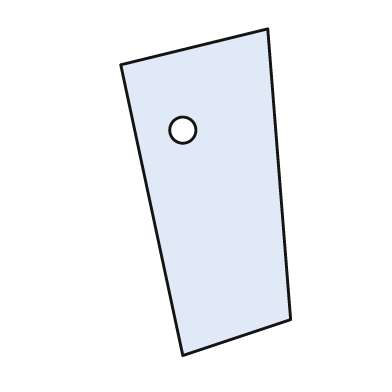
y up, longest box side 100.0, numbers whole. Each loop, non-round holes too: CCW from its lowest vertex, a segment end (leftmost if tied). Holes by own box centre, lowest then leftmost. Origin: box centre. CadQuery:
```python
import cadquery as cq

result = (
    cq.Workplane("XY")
    .moveTo(-7.0, -50.0)
    .lineTo(26.0, -39.0)
    .lineTo(19.0, 50.0)
    .lineTo(-26.0, 39.0)
    .close()
    .moveTo(-7.0, 19.0)
    .circle(4.0)
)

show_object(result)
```